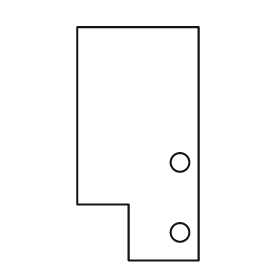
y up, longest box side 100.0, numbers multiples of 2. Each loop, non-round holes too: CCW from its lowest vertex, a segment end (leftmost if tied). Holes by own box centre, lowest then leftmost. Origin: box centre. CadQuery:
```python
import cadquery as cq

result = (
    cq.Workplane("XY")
    .moveTo(-4.0, -50.0)
    .lineTo(26.0, -50.0)
    .lineTo(26.0, 50.0)
    .lineTo(-26.0, 50.0)
    .lineTo(-26.0, -26.0)
    .lineTo(-4.0, -26.0)
    .close()
    .moveTo(18.0, -38.0)
    .circle(4.0)
    .moveTo(18.0, -8.0)
    .circle(4.0)
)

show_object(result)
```